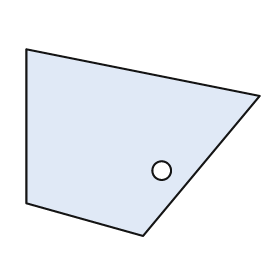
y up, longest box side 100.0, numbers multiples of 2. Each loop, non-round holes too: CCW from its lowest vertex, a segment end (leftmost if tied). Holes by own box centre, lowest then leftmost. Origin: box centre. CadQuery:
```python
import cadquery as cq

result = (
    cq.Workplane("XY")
    .moveTo(0.0, -40.0)
    .lineTo(50.0, 20.0)
    .lineTo(-50.0, 40.0)
    .lineTo(-50.0, -26.0)
    .close()
    .moveTo(8.0, -12.0)
    .circle(4.0)
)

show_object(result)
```